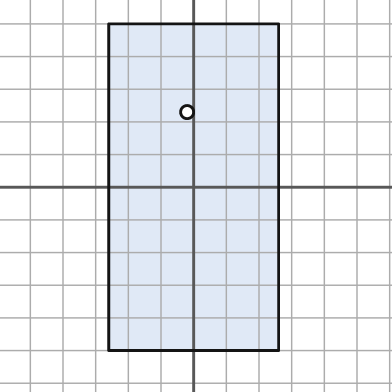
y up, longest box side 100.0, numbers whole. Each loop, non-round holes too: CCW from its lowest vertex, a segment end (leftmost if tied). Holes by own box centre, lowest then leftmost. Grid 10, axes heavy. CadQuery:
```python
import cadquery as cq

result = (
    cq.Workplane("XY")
    .moveTo(-26.0, -50.0)
    .lineTo(26.0, -50.0)
    .lineTo(26.0, 50.0)
    .lineTo(-26.0, 50.0)
    .close()
    .moveTo(-2.0, 23.0)
    .circle(2.0)
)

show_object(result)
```